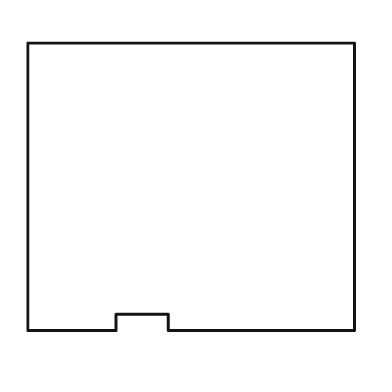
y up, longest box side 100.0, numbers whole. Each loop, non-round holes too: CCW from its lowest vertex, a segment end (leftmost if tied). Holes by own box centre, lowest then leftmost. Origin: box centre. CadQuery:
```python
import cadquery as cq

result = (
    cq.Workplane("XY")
    .moveTo(-50.0, -44.0)
    .lineTo(-23.0, -44.0)
    .lineTo(-23.0, -39.0)
    .lineTo(-7.0, -39.0)
    .lineTo(-7.0, -44.0)
    .lineTo(50.0, -44.0)
    .lineTo(50.0, 44.0)
    .lineTo(-50.0, 44.0)
    .close()
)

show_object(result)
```